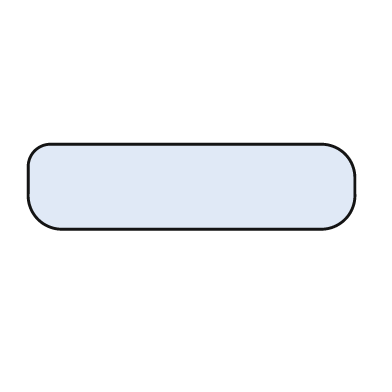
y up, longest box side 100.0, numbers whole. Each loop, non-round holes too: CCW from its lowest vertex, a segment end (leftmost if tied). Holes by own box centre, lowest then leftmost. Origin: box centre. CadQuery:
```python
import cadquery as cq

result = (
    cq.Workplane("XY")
    .moveTo(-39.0, -13.0)
    .lineTo(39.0, -13.0)
    .threePointArc((47.0, -10.0), (50.0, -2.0))
    .lineTo(50.0, 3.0)
    .threePointArc((47.0, 10.0), (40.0, 13.0))
    .lineTo(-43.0, 13.0)
    .threePointArc((-48.0, 11.0), (-50.0, 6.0))
    .lineTo(-50.0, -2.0)
    .threePointArc((-47.0, -10.0), (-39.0, -13.0))
    .close()
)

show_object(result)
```